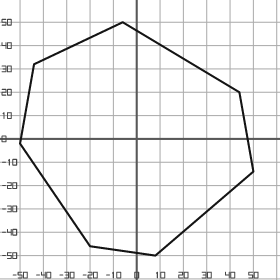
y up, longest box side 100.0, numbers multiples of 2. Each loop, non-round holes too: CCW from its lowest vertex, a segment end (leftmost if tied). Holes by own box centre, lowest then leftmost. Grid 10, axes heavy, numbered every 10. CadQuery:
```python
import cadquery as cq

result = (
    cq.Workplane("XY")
    .moveTo(8.0, -50.0)
    .lineTo(50.0, -14.0)
    .lineTo(44.0, 20.0)
    .lineTo(-6.0, 50.0)
    .lineTo(-44.0, 32.0)
    .lineTo(-50.0, -2.0)
    .lineTo(-20.0, -46.0)
    .close()
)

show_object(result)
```